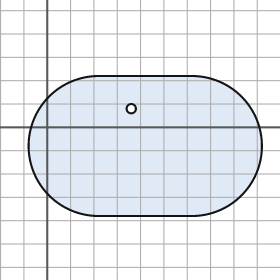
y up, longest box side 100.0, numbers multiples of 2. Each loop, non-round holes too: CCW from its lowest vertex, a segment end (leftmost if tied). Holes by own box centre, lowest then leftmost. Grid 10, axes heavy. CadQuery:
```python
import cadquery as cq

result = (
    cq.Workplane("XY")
    .moveTo(22.0, -38.0)
    .lineTo(62.0, -38.0)
    .threePointArc((92.0, -8.0), (62.0, 22.0))
    .lineTo(22.0, 22.0)
    .threePointArc((-8.0, -8.0), (22.0, -38.0))
    .close()
    .moveTo(36.0, 8.0)
    .circle(2.0)
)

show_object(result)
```